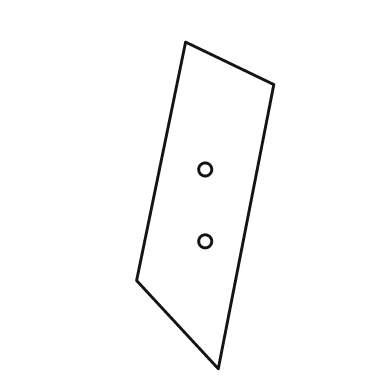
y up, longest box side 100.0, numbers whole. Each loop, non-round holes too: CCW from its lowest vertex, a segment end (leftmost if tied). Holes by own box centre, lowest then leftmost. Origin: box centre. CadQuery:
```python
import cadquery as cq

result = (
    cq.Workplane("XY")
    .moveTo(4.0, -50.0)
    .lineTo(21.0, 37.0)
    .lineTo(-6.0, 50.0)
    .lineTo(-21.0, -23.0)
    .close()
    .moveTo(0.0, -11.0)
    .circle(2.0)
    .moveTo(0.0, 11.0)
    .circle(2.0)
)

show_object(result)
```